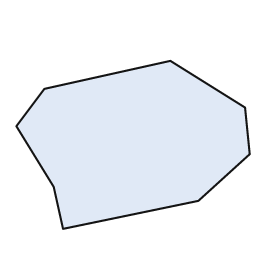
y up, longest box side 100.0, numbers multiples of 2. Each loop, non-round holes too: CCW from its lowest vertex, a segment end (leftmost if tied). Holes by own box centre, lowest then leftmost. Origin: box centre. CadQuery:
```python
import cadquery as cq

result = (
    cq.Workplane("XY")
    .moveTo(-30.0, -36.0)
    .lineTo(28.0, -24.0)
    .lineTo(50.0, -4.0)
    .lineTo(48.0, 16.0)
    .lineTo(16.0, 36.0)
    .lineTo(-38.0, 24.0)
    .lineTo(-50.0, 8.0)
    .lineTo(-34.0, -18.0)
    .close()
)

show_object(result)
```